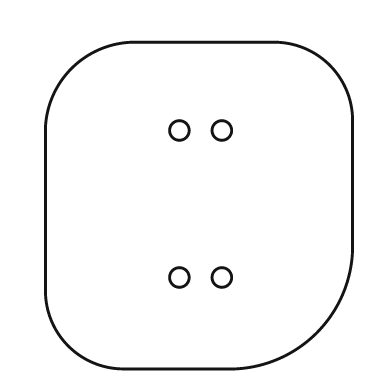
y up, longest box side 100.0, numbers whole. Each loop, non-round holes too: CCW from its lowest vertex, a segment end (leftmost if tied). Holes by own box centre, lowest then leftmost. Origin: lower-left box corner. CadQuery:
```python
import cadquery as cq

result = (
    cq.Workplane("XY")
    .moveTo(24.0, 0.0)
    .lineTo(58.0, 0.0)
    .threePointArc((83.0, 11.0), (94.0, 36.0))
    .lineTo(94.0, 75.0)
    .threePointArc((87.0, 93.0), (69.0, 100.0))
    .lineTo(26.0, 100.0)
    .threePointArc((8.0, 92.0), (0.0, 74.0))
    .lineTo(0.0, 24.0)
    .threePointArc((7.0, 7.0), (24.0, 0.0))
    .close()
    .moveTo(41.0, 28.0)
    .circle(3.0)
    .moveTo(54.0, 28.0)
    .circle(3.0)
    .moveTo(41.0, 73.0)
    .circle(3.0)
    .moveTo(54.0, 73.0)
    .circle(3.0)
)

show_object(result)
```